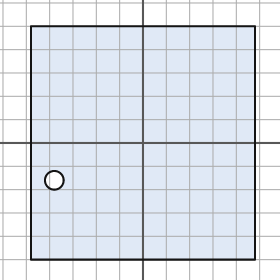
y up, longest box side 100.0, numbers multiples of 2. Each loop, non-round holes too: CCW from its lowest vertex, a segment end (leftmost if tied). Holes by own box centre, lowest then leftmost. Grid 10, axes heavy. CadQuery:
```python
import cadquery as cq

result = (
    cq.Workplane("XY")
    .moveTo(-48.0, -50.0)
    .lineTo(48.0, -50.0)
    .lineTo(48.0, 50.0)
    .lineTo(-48.0, 50.0)
    .close()
    .moveTo(-38.0, -16.0)
    .circle(4.0)
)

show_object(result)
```